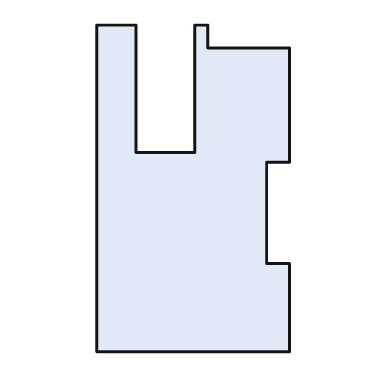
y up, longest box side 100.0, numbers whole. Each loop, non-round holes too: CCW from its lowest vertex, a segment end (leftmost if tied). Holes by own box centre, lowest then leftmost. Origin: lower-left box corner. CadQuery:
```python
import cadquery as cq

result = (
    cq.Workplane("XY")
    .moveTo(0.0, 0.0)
    .lineTo(59.0, 0.0)
    .lineTo(59.0, 27.0)
    .lineTo(52.0, 27.0)
    .lineTo(52.0, 58.0)
    .lineTo(59.0, 58.0)
    .lineTo(59.0, 93.0)
    .lineTo(34.0, 93.0)
    .lineTo(34.0, 100.0)
    .lineTo(30.0, 100.0)
    .lineTo(30.0, 61.0)
    .lineTo(12.0, 61.0)
    .lineTo(12.0, 100.0)
    .lineTo(0.0, 100.0)
    .close()
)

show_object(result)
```